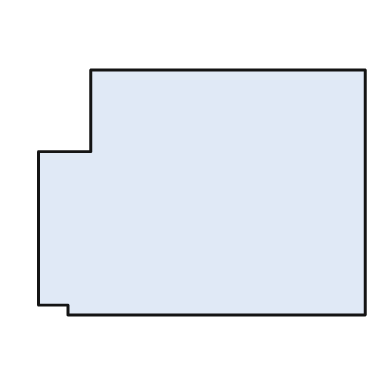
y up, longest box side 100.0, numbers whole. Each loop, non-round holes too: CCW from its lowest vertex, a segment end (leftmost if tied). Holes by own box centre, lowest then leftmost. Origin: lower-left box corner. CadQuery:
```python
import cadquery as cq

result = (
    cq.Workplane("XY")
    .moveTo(9.0, 0.0)
    .lineTo(100.0, 0.0)
    .lineTo(100.0, 75.0)
    .lineTo(16.0, 75.0)
    .lineTo(16.0, 50.0)
    .lineTo(0.0, 50.0)
    .lineTo(0.0, 3.0)
    .lineTo(9.0, 3.0)
    .close()
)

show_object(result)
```